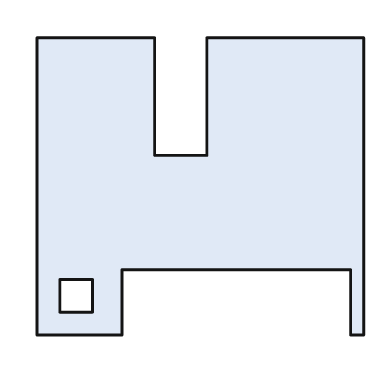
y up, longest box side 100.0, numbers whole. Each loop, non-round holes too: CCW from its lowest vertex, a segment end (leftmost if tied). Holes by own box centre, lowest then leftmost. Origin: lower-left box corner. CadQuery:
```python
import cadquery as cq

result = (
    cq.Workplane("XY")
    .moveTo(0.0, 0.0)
    .lineTo(26.0, 0.0)
    .lineTo(26.0, 20.0)
    .lineTo(96.0, 20.0)
    .lineTo(96.0, 0.0)
    .lineTo(100.0, 0.0)
    .lineTo(100.0, 91.0)
    .lineTo(52.0, 91.0)
    .lineTo(52.0, 55.0)
    .lineTo(36.0, 55.0)
    .lineTo(36.0, 91.0)
    .lineTo(0.0, 91.0)
    .close()
    .moveTo(7.0, 7.0)
    .lineTo(17.0, 7.0)
    .lineTo(17.0, 17.0)
    .lineTo(7.0, 17.0)
    .close()
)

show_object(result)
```